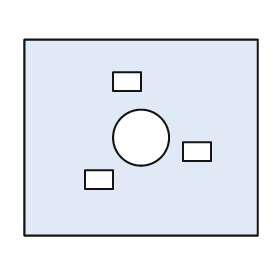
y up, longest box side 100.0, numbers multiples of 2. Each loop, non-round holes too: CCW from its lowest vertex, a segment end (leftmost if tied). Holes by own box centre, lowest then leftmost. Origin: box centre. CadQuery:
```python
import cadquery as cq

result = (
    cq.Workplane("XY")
    .moveTo(-50.0, -42.0)
    .lineTo(50.0, -42.0)
    .lineTo(50.0, 42.0)
    .lineTo(-50.0, 42.0)
    .close()
    .moveTo(-24.0, -22.0)
    .lineTo(-12.0, -22.0)
    .lineTo(-12.0, -14.0)
    .lineTo(-24.0, -14.0)
    .close()
    .moveTo(18.0, -10.0)
    .lineTo(30.0, -10.0)
    .lineTo(30.0, -2.0)
    .lineTo(18.0, -2.0)
    .close()
    .moveTo(0.0, 0.0)
    .circle(12.0)
    .moveTo(-12.0, 20.0)
    .lineTo(0.0, 20.0)
    .lineTo(0.0, 28.0)
    .lineTo(-12.0, 28.0)
    .close()
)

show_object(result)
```